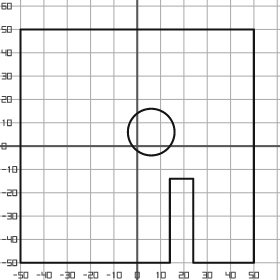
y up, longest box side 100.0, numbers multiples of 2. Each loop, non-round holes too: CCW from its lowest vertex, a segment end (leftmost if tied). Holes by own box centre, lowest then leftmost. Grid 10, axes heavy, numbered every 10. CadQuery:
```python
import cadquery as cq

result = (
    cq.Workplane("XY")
    .moveTo(-50.0, -50.0)
    .lineTo(14.0, -50.0)
    .lineTo(14.0, -14.0)
    .lineTo(24.0, -14.0)
    .lineTo(24.0, -50.0)
    .lineTo(50.0, -50.0)
    .lineTo(50.0, 50.0)
    .lineTo(-50.0, 50.0)
    .close()
    .moveTo(6.0, 6.0)
    .circle(10.0)
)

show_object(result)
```